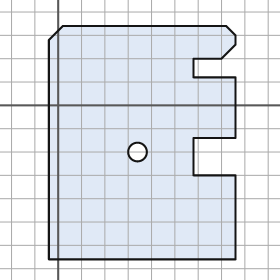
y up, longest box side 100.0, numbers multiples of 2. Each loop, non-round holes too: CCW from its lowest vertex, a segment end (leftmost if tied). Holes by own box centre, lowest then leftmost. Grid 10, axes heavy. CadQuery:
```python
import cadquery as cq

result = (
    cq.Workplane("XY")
    .moveTo(-4.0, -66.0)
    .lineTo(76.0, -66.0)
    .lineTo(76.0, -30.0)
    .lineTo(58.0, -30.0)
    .lineTo(58.0, -14.0)
    .lineTo(76.0, -14.0)
    .lineTo(76.0, 12.0)
    .lineTo(58.0, 12.0)
    .lineTo(58.0, 20.0)
    .lineTo(70.0, 20.0)
    .lineTo(76.0, 26.0)
    .lineTo(76.0, 30.0)
    .lineTo(72.0, 34.0)
    .lineTo(2.0, 34.0)
    .lineTo(-4.0, 28.0)
    .close()
    .moveTo(34.0, -20.0)
    .circle(4.0)
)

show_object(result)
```